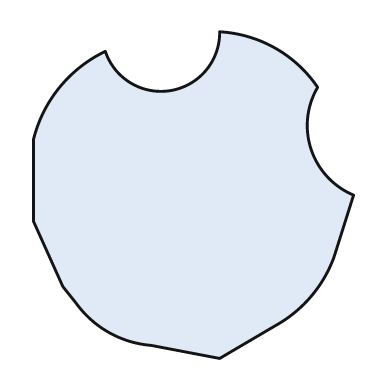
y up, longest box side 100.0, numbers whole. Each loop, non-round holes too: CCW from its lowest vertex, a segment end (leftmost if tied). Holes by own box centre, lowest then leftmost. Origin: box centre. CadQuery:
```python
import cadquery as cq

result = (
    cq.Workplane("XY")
    .moveTo(8.0, -50.0)
    .lineTo(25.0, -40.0)
    .threePointArc((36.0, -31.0), (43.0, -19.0))
    .lineTo(49.0, 0.0)
    .threePointArc((36.0, 14.0), (38.0, 33.0))
    .threePointArc((25.0, 45.0), (8.0, 50.0))
    .threePointArc((-7.0, 32.0), (-27.0, 44.0))
    .threePointArc((-41.0, 33.0), (-49.0, 17.0))
    .lineTo(-49.0, -8.0)
    .lineTo(-40.0, -28.0)
    .lineTo(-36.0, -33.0)
    .threePointArc((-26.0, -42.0), (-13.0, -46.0))
    .close()
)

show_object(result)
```